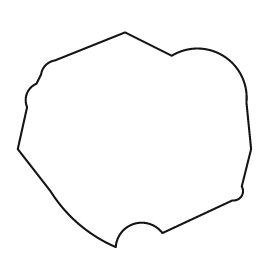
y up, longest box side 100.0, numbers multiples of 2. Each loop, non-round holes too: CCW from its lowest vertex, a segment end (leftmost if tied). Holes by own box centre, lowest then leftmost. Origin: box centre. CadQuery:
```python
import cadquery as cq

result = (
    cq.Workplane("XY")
    .moveTo(-8.0, -46.0)
    .threePointArc((0.0, -36.0), (12.0, -40.0))
    .lineTo(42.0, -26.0)
    .threePointArc((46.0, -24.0), (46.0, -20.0))
    .lineTo(50.0, -4.0)
    .lineTo(48.0, 16.0)
    .threePointArc((38.0, 36.0), (16.0, 36.0))
    .lineTo(-4.0, 46.0)
    .lineTo(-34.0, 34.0)
    .threePointArc((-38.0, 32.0), (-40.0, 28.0))
    .lineTo(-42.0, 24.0)
    .threePointArc((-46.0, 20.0), (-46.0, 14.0))
    .lineTo(-50.0, -4.0)
    .lineTo(-36.0, -22.0)
    .threePointArc((-24.0, -36.0), (-8.0, -46.0))
    .close()
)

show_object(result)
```